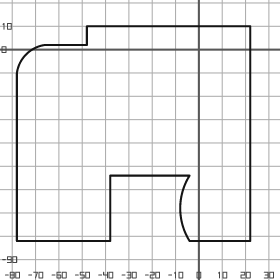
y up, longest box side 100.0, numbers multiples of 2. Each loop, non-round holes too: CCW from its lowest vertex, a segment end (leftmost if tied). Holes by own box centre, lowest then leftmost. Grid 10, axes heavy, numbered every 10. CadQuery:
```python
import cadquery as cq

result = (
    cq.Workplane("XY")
    .moveTo(-78.0, -82.0)
    .lineTo(-38.0, -82.0)
    .lineTo(-38.0, -54.0)
    .lineTo(-4.0, -54.0)
    .threePointArc((-8.0, -68.0), (-4.0, -82.0))
    .lineTo(22.0, -82.0)
    .lineTo(22.0, 10.0)
    .lineTo(-48.0, 10.0)
    .lineTo(-48.0, 2.0)
    .lineTo(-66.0, 2.0)
    .threePointArc((-74.0, -2.0), (-78.0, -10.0))
    .close()
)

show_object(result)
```